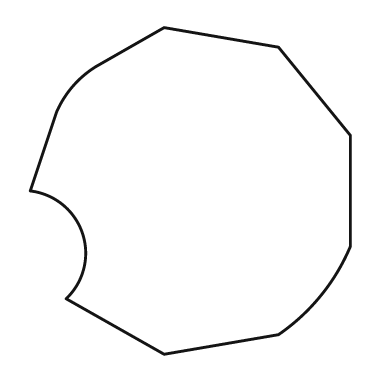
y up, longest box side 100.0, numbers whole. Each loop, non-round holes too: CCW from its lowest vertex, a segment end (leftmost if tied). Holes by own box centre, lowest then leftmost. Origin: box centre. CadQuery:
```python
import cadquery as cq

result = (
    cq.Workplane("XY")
    .moveTo(-8.0, -50.0)
    .lineTo(27.0, -44.0)
    .threePointArc((40.0, -32.0), (49.0, -17.0))
    .lineTo(49.0, 17.0)
    .lineTo(27.0, 44.0)
    .lineTo(-8.0, 50.0)
    .lineTo(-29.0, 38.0)
    .threePointArc((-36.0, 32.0), (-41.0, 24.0))
    .lineTo(-49.0, 0.0)
    .threePointArc((-33.0, -13.0), (-38.0, -33.0))
    .close()
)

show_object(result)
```